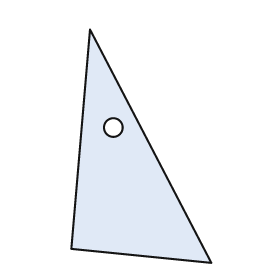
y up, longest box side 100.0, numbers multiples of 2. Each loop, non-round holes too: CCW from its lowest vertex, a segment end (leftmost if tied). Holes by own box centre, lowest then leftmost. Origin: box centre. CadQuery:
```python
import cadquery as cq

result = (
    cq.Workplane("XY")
    .moveTo(30.0, -50.0)
    .lineTo(-22.0, 50.0)
    .lineTo(-30.0, -44.0)
    .close()
    .moveTo(-12.0, 8.0)
    .circle(4.0)
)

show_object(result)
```